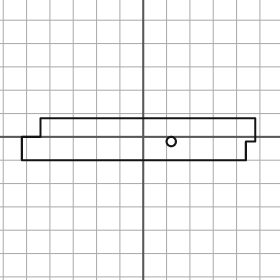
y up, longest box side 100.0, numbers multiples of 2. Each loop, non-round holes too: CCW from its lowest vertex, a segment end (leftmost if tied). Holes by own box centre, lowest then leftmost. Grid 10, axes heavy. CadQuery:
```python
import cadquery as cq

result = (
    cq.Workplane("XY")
    .moveTo(-52.0, -10.0)
    .lineTo(44.0, -10.0)
    .lineTo(44.0, -2.0)
    .lineTo(48.0, -2.0)
    .lineTo(48.0, 8.0)
    .lineTo(-44.0, 8.0)
    .lineTo(-44.0, 0.0)
    .lineTo(-52.0, 0.0)
    .close()
    .moveTo(12.0, -2.0)
    .circle(2.0)
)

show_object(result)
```